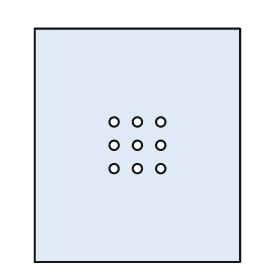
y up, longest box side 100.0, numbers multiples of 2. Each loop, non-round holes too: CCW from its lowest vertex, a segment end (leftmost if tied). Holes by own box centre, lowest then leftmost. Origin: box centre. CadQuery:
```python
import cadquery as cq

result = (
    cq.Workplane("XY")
    .moveTo(-44.0, -50.0)
    .lineTo(44.0, -50.0)
    .lineTo(44.0, 50.0)
    .lineTo(-44.0, 50.0)
    .close()
    .moveTo(-10.0, -10.0)
    .circle(2.0)
    .moveTo(0.0, -10.0)
    .circle(2.0)
    .moveTo(10.0, -10.0)
    .circle(2.0)
    .moveTo(-10.0, 0.0)
    .circle(2.0)
    .moveTo(0.0, 0.0)
    .circle(2.0)
    .moveTo(10.0, 0.0)
    .circle(2.0)
    .moveTo(-10.0, 10.0)
    .circle(2.0)
    .moveTo(0.0, 10.0)
    .circle(2.0)
    .moveTo(10.0, 10.0)
    .circle(2.0)
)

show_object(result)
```